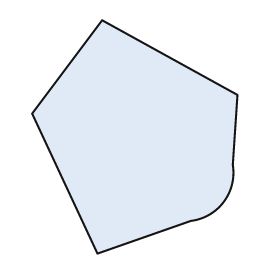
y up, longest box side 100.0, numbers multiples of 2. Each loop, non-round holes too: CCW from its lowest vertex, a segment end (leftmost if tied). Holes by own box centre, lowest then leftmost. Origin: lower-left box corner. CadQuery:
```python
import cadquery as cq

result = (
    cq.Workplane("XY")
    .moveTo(28.0, 0.0)
    .lineTo(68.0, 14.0)
    .threePointArc((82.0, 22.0), (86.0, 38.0))
    .lineTo(88.0, 68.0)
    .lineTo(30.0, 100.0)
    .lineTo(0.0, 60.0)
    .close()
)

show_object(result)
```